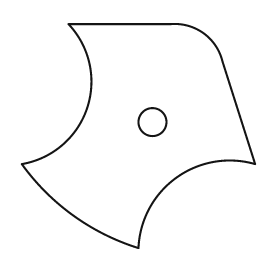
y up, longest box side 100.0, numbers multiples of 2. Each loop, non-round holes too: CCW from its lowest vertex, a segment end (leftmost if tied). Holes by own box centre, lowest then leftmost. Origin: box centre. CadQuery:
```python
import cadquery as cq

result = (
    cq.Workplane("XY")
    .moveTo(0.0, -48.0)
    .threePointArc((16.0, -18.0), (50.0, -12.0))
    .lineTo(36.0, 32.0)
    .threePointArc((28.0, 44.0), (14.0, 48.0))
    .lineTo(-30.0, 48.0)
    .threePointArc((-22.0, 12.0), (-50.0, -12.0))
    .threePointArc((-28.0, -34.0), (0.0, -48.0))
    .close()
    .moveTo(6.0, 6.0)
    .circle(6.0)
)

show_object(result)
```